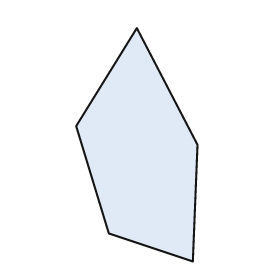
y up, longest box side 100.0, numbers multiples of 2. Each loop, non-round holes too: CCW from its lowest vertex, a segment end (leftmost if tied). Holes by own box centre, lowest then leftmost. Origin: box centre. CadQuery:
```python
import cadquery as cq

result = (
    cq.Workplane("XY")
    .moveTo(24.0, -50.0)
    .lineTo(26.0, 0.0)
    .lineTo(0.0, 50.0)
    .lineTo(-26.0, 8.0)
    .lineTo(-12.0, -38.0)
    .close()
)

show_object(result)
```